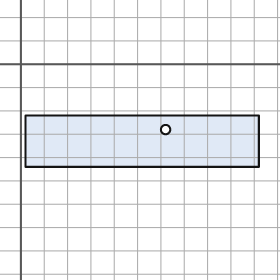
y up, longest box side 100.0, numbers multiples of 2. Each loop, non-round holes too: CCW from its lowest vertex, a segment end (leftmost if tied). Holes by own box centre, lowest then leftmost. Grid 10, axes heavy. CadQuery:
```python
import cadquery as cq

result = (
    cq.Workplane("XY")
    .moveTo(2.0, -44.0)
    .lineTo(102.0, -44.0)
    .lineTo(102.0, -22.0)
    .lineTo(2.0, -22.0)
    .close()
    .moveTo(62.0, -28.0)
    .circle(2.0)
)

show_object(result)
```